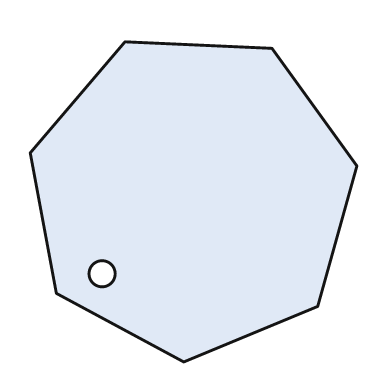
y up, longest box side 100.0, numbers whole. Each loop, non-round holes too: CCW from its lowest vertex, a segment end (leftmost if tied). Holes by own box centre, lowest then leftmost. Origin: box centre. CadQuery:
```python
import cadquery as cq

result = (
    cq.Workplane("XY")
    .moveTo(-3.0, -49.0)
    .lineTo(38.0, -32.0)
    .lineTo(50.0, 11.0)
    .lineTo(24.0, 47.0)
    .lineTo(-21.0, 49.0)
    .lineTo(-50.0, 15.0)
    .lineTo(-42.0, -28.0)
    .close()
    .moveTo(-28.0, -22.0)
    .circle(4.0)
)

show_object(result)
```